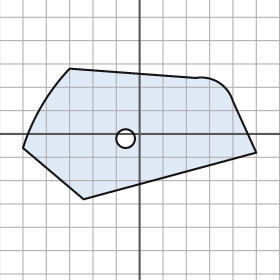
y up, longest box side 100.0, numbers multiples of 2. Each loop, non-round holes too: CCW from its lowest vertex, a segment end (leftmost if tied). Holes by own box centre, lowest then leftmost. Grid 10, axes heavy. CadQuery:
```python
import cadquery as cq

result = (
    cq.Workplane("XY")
    .moveTo(-24.0, -28.0)
    .lineTo(50.0, -8.0)
    .lineTo(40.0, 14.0)
    .threePointArc((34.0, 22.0), (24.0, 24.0))
    .lineTo(-30.0, 28.0)
    .threePointArc((-42.0, 12.0), (-50.0, -6.0))
    .close()
    .moveTo(-6.0, -2.0)
    .circle(4.0)
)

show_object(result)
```